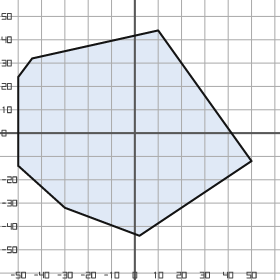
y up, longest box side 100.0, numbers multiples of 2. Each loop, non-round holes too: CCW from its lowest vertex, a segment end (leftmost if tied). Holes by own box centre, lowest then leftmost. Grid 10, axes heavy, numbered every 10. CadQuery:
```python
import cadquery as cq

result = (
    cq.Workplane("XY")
    .moveTo(2.0, -44.0)
    .lineTo(50.0, -12.0)
    .lineTo(10.0, 44.0)
    .lineTo(-44.0, 32.0)
    .lineTo(-50.0, 24.0)
    .lineTo(-50.0, -14.0)
    .lineTo(-30.0, -32.0)
    .close()
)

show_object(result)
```